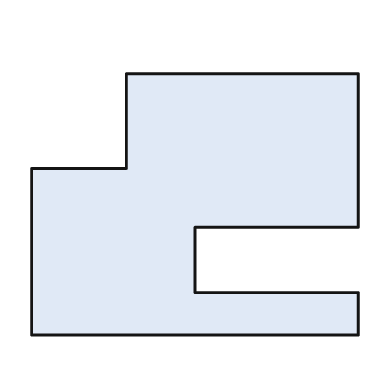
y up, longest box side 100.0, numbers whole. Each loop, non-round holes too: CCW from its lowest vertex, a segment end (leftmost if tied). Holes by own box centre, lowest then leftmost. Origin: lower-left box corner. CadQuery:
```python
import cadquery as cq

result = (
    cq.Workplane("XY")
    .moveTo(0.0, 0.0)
    .lineTo(100.0, 0.0)
    .lineTo(100.0, 13.0)
    .lineTo(50.0, 13.0)
    .lineTo(50.0, 33.0)
    .lineTo(100.0, 33.0)
    .lineTo(100.0, 80.0)
    .lineTo(29.0, 80.0)
    .lineTo(29.0, 51.0)
    .lineTo(0.0, 51.0)
    .close()
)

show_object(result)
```